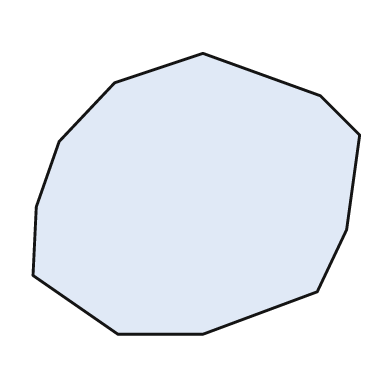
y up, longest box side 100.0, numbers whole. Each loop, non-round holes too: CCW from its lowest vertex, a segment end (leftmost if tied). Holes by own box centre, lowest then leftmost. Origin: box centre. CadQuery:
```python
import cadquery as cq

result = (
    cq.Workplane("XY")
    .moveTo(-24.0, -43.0)
    .lineTo(2.0, -43.0)
    .lineTo(37.0, -30.0)
    .lineTo(46.0, -11.0)
    .lineTo(50.0, 18.0)
    .lineTo(38.0, 30.0)
    .lineTo(2.0, 43.0)
    .lineTo(-25.0, 34.0)
    .lineTo(-42.0, 16.0)
    .lineTo(-49.0, -4.0)
    .lineTo(-50.0, -25.0)
    .close()
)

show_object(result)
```